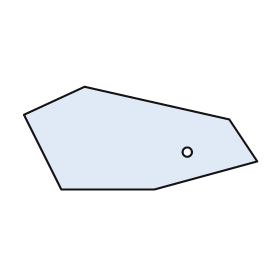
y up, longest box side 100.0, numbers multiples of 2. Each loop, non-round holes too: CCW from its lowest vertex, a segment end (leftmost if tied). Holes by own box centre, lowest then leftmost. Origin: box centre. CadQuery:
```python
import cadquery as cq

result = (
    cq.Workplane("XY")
    .moveTo(-34.0, -22.0)
    .lineTo(6.0, -22.0)
    .lineTo(50.0, -10.0)
    .lineTo(38.0, 8.0)
    .lineTo(-24.0, 22.0)
    .lineTo(-50.0, 10.0)
    .close()
    .moveTo(20.0, -6.0)
    .circle(2.0)
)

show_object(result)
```